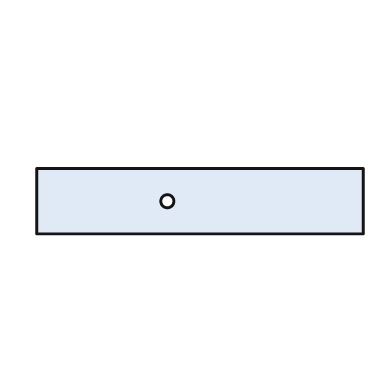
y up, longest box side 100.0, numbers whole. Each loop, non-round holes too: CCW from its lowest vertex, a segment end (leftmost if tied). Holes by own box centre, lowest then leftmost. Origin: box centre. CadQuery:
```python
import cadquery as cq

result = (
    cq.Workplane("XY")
    .moveTo(-50.0, -10.0)
    .lineTo(50.0, -10.0)
    .lineTo(50.0, 10.0)
    .lineTo(-50.0, 10.0)
    .close()
    .moveTo(-10.0, 0.0)
    .circle(2.0)
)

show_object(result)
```